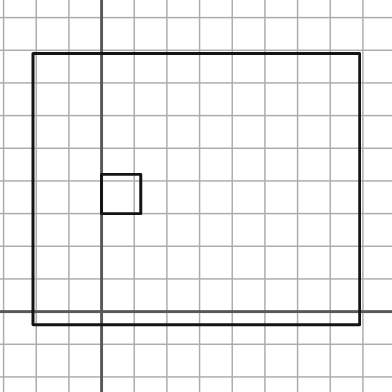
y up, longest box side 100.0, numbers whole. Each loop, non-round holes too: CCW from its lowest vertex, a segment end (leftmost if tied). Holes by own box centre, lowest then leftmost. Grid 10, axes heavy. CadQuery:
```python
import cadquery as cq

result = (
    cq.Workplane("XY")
    .moveTo(-21.0, -4.0)
    .lineTo(79.0, -4.0)
    .lineTo(79.0, 79.0)
    .lineTo(-21.0, 79.0)
    .close()
    .moveTo(0.0, 30.0)
    .lineTo(12.0, 30.0)
    .lineTo(12.0, 42.0)
    .lineTo(0.0, 42.0)
    .close()
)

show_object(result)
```